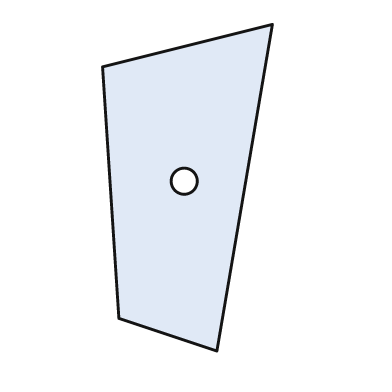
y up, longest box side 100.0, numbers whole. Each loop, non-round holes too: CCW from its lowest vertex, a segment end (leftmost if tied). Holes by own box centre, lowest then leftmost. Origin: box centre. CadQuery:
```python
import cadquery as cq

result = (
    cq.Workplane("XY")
    .moveTo(9.0, -50.0)
    .lineTo(26.0, 50.0)
    .lineTo(-26.0, 37.0)
    .lineTo(-21.0, -40.0)
    .close()
    .moveTo(-1.0, 2.0)
    .circle(4.0)
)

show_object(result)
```